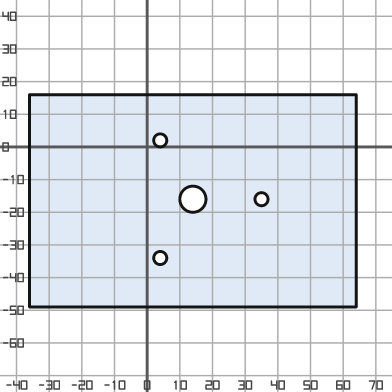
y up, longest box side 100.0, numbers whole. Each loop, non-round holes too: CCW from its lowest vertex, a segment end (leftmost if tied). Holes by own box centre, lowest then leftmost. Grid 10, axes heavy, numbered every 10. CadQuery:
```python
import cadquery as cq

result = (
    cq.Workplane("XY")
    .moveTo(-36.0, -49.0)
    .lineTo(64.0, -49.0)
    .lineTo(64.0, 16.0)
    .lineTo(-36.0, 16.0)
    .close()
    .moveTo(4.0, -34.0)
    .circle(2.0)
    .moveTo(14.0, -16.0)
    .circle(4.0)
    .moveTo(35.0, -16.0)
    .circle(2.0)
    .moveTo(4.0, 2.0)
    .circle(2.0)
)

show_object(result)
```